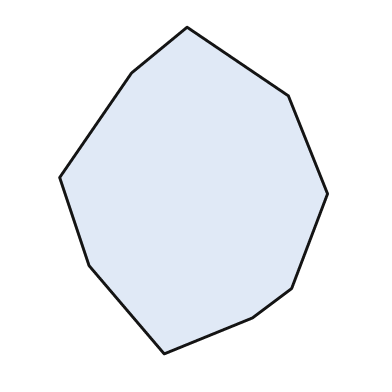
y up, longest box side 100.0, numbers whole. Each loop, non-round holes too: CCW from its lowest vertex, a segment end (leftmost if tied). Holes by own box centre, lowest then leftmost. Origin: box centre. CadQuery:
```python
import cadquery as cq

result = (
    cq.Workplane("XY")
    .moveTo(-9.0, -50.0)
    .lineTo(18.0, -39.0)
    .lineTo(30.0, -30.0)
    .lineTo(41.0, -1.0)
    .lineTo(29.0, 29.0)
    .lineTo(-2.0, 50.0)
    .lineTo(-19.0, 36.0)
    .lineTo(-41.0, 4.0)
    .lineTo(-32.0, -23.0)
    .close()
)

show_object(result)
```